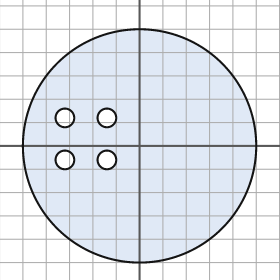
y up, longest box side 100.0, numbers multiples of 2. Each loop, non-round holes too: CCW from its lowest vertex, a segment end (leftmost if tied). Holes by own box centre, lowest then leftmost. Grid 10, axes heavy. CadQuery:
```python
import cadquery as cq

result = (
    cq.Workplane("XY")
    .moveTo(0.0, 0.0)
    .circle(50.0)
    .moveTo(-32.0, -6.0)
    .circle(4.0)
    .moveTo(-14.0, -6.0)
    .circle(4.0)
    .moveTo(-32.0, 12.0)
    .circle(4.0)
    .moveTo(-14.0, 12.0)
    .circle(4.0)
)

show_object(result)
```